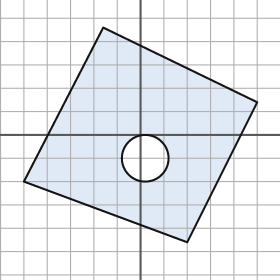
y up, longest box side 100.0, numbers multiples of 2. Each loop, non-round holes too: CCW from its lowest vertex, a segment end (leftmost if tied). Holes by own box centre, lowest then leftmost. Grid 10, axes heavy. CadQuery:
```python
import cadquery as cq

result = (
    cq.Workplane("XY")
    .moveTo(20.0, -46.0)
    .lineTo(50.0, 14.0)
    .lineTo(-16.0, 46.0)
    .lineTo(-50.0, -20.0)
    .close()
    .moveTo(2.0, -10.0)
    .circle(10.0)
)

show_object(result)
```